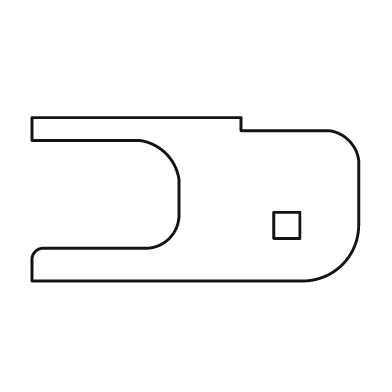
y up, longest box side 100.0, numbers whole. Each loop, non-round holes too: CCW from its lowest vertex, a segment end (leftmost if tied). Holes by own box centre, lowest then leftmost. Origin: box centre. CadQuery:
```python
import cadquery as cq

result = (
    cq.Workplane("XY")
    .moveTo(-50.0, -25.0)
    .lineTo(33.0, -25.0)
    .threePointArc((45.0, -20.0), (50.0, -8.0))
    .lineTo(50.0, 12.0)
    .threePointArc((47.0, 18.0), (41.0, 21.0))
    .lineTo(14.0, 21.0)
    .lineTo(14.0, 25.0)
    .lineTo(-50.0, 25.0)
    .lineTo(-50.0, 18.0)
    .lineTo(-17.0, 18.0)
    .threePointArc((-9.0, 14.0), (-5.0, 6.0))
    .lineTo(-5.0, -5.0)
    .threePointArc((-8.0, -12.0), (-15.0, -15.0))
    .lineTo(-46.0, -15.0)
    .threePointArc((-49.0, -16.0), (-50.0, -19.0))
    .close()
    .moveTo(24.0, -12.0)
    .lineTo(32.0, -12.0)
    .lineTo(32.0, -4.0)
    .lineTo(24.0, -4.0)
    .close()
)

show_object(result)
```